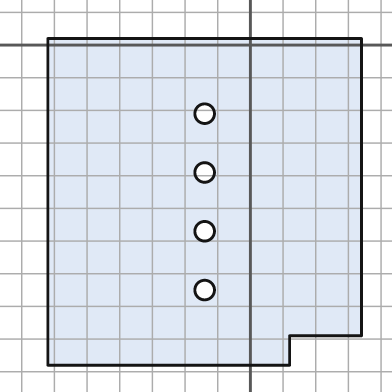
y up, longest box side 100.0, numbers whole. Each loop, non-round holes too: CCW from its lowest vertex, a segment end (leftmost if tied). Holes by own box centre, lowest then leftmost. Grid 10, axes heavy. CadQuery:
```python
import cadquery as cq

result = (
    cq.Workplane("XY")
    .moveTo(-62.0, -98.0)
    .lineTo(12.0, -98.0)
    .lineTo(12.0, -89.0)
    .lineTo(34.0, -89.0)
    .lineTo(34.0, 2.0)
    .lineTo(-62.0, 2.0)
    .close()
    .moveTo(-14.0, -75.0)
    .circle(3.0)
    .moveTo(-14.0, -57.0)
    .circle(3.0)
    .moveTo(-14.0, -39.0)
    .circle(3.0)
    .moveTo(-14.0, -21.0)
    .circle(3.0)
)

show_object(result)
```